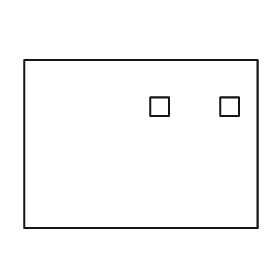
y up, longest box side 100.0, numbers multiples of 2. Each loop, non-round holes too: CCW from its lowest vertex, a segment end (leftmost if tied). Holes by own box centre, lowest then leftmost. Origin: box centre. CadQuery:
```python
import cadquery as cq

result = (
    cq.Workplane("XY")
    .moveTo(-50.0, -36.0)
    .lineTo(50.0, -36.0)
    .lineTo(50.0, 36.0)
    .lineTo(-50.0, 36.0)
    .close()
    .moveTo(4.0, 12.0)
    .lineTo(12.0, 12.0)
    .lineTo(12.0, 20.0)
    .lineTo(4.0, 20.0)
    .close()
    .moveTo(34.0, 12.0)
    .lineTo(42.0, 12.0)
    .lineTo(42.0, 20.0)
    .lineTo(34.0, 20.0)
    .close()
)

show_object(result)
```